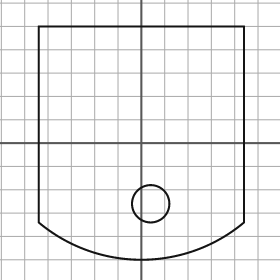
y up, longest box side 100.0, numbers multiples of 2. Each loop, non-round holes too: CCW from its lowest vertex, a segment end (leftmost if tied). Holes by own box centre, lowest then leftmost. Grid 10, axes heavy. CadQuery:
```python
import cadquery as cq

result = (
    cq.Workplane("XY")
    .moveTo(-44.0, -34.0)
    .threePointArc((0.0, -50.0), (44.0, -34.0))
    .lineTo(44.0, 50.0)
    .lineTo(-44.0, 50.0)
    .close()
    .moveTo(4.0, -26.0)
    .circle(8.0)
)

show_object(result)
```